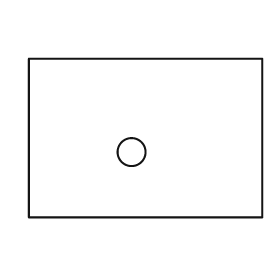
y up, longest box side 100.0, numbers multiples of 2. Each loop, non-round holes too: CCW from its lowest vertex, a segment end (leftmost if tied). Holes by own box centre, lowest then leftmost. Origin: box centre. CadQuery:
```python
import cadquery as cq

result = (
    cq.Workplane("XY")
    .moveTo(-50.0, -34.0)
    .lineTo(50.0, -34.0)
    .lineTo(50.0, 34.0)
    .lineTo(-50.0, 34.0)
    .close()
    .moveTo(-6.0, -6.0)
    .circle(6.0)
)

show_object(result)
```